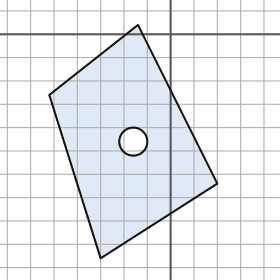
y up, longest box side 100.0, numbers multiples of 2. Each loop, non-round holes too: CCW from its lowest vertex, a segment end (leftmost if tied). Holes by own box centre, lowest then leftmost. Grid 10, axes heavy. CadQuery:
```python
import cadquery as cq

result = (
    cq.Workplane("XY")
    .moveTo(-30.0, -96.0)
    .lineTo(20.0, -64.0)
    .lineTo(-14.0, 4.0)
    .lineTo(-52.0, -26.0)
    .close()
    .moveTo(-16.0, -46.0)
    .circle(6.0)
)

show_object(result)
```